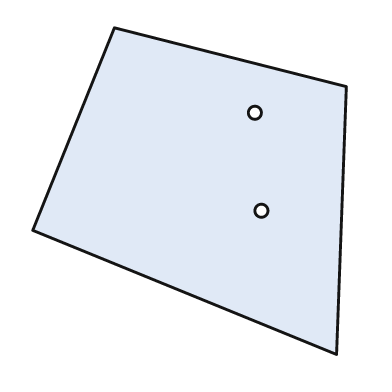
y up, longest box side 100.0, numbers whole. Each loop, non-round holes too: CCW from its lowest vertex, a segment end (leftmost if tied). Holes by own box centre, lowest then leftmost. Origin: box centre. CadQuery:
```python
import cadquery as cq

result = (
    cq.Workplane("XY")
    .moveTo(45.0, -50.0)
    .lineTo(48.0, 32.0)
    .lineTo(-23.0, 50.0)
    .lineTo(-48.0, -12.0)
    .close()
    .moveTo(22.0, -6.0)
    .circle(2.0)
    .moveTo(20.0, 24.0)
    .circle(2.0)
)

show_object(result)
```